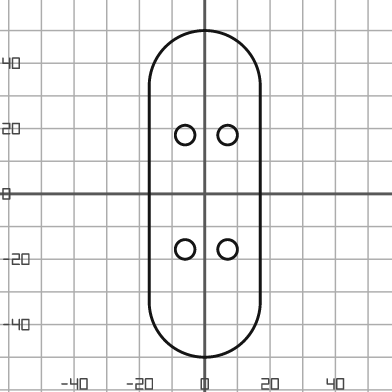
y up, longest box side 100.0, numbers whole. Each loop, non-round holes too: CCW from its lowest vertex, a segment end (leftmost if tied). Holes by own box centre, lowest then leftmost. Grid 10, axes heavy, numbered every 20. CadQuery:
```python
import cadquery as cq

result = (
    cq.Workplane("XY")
    .moveTo(-17.0, -33.0)
    .threePointArc((0.0, -50.0), (17.0, -33.0))
    .lineTo(17.0, 33.0)
    .threePointArc((0.0, 50.0), (-17.0, 33.0))
    .close()
    .moveTo(-6.0, -17.0)
    .circle(3.0)
    .moveTo(7.0, -17.0)
    .circle(3.0)
    .moveTo(-6.0, 18.0)
    .circle(3.0)
    .moveTo(7.0, 18.0)
    .circle(3.0)
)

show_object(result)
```